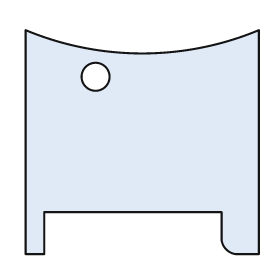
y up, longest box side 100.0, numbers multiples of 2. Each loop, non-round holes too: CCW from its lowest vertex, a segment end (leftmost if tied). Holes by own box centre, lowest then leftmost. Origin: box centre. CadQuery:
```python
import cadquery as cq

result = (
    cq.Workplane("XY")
    .moveTo(-50.0, -48.0)
    .lineTo(-42.0, -48.0)
    .lineTo(-42.0, -30.0)
    .lineTo(34.0, -30.0)
    .lineTo(34.0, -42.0)
    .threePointArc((36.0, -46.0), (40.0, -48.0))
    .lineTo(50.0, -48.0)
    .lineTo(50.0, 48.0)
    .threePointArc((0.0, 38.0), (-50.0, 48.0))
    .close()
    .moveTo(-20.0, 28.0)
    .circle(6.0)
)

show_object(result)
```